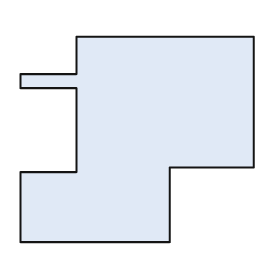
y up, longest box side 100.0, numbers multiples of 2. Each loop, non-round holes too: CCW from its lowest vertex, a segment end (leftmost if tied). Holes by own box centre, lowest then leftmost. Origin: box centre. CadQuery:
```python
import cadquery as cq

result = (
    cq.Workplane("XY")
    .moveTo(-50.0, -44.0)
    .lineTo(14.0, -44.0)
    .lineTo(14.0, -12.0)
    .lineTo(50.0, -12.0)
    .lineTo(50.0, 44.0)
    .lineTo(-26.0, 44.0)
    .lineTo(-26.0, 28.0)
    .lineTo(-50.0, 28.0)
    .lineTo(-50.0, 22.0)
    .lineTo(-26.0, 22.0)
    .lineTo(-26.0, -14.0)
    .lineTo(-50.0, -14.0)
    .close()
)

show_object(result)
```